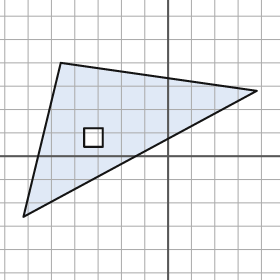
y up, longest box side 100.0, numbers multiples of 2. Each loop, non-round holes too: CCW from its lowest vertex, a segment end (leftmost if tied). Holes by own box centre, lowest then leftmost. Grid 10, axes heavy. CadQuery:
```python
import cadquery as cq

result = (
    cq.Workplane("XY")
    .moveTo(-62.0, -26.0)
    .lineTo(38.0, 28.0)
    .lineTo(-46.0, 40.0)
    .close()
    .moveTo(-36.0, 4.0)
    .lineTo(-28.0, 4.0)
    .lineTo(-28.0, 12.0)
    .lineTo(-36.0, 12.0)
    .close()
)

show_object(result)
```